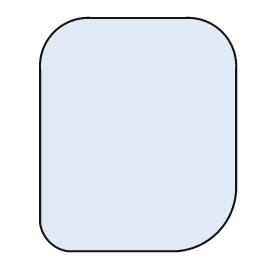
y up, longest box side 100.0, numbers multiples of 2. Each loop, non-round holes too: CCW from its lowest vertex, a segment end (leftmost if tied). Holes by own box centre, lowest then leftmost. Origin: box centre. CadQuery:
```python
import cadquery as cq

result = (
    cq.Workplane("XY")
    .moveTo(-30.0, -50.0)
    .lineTo(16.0, -50.0)
    .threePointArc((34.0, -42.0), (42.0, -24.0))
    .lineTo(42.0, 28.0)
    .threePointArc((36.0, 44.0), (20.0, 50.0))
    .lineTo(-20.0, 50.0)
    .threePointArc((-36.0, 44.0), (-42.0, 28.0))
    .lineTo(-42.0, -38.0)
    .threePointArc((-38.0, -46.0), (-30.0, -50.0))
    .close()
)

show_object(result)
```